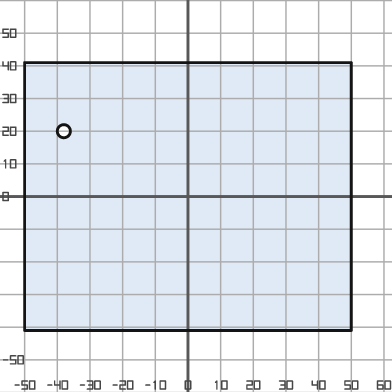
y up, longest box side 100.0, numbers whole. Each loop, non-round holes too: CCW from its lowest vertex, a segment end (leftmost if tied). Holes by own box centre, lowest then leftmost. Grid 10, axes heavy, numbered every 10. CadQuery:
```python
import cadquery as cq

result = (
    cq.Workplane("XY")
    .moveTo(-50.0, -41.0)
    .lineTo(50.0, -41.0)
    .lineTo(50.0, 41.0)
    .lineTo(-50.0, 41.0)
    .close()
    .moveTo(-38.0, 20.0)
    .circle(2.0)
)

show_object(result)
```